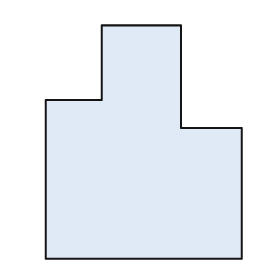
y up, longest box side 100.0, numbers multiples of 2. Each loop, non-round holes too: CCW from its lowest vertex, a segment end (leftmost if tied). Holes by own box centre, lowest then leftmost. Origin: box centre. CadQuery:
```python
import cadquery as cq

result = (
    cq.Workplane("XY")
    .moveTo(-42.0, -50.0)
    .lineTo(42.0, -50.0)
    .lineTo(42.0, 6.0)
    .lineTo(16.0, 6.0)
    .lineTo(16.0, 50.0)
    .lineTo(-18.0, 50.0)
    .lineTo(-18.0, 18.0)
    .lineTo(-42.0, 18.0)
    .close()
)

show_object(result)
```